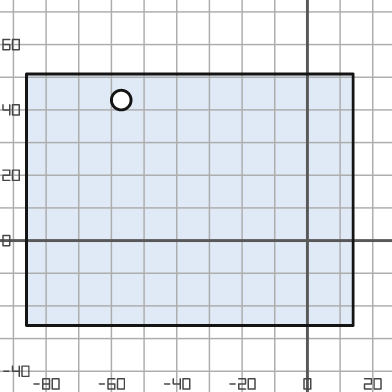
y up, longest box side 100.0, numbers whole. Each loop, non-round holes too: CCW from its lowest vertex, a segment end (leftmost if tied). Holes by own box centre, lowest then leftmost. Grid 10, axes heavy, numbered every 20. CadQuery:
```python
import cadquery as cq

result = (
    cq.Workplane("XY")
    .moveTo(-86.0, -26.0)
    .lineTo(14.0, -26.0)
    .lineTo(14.0, 51.0)
    .lineTo(-86.0, 51.0)
    .close()
    .moveTo(-57.0, 43.0)
    .circle(3.0)
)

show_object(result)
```